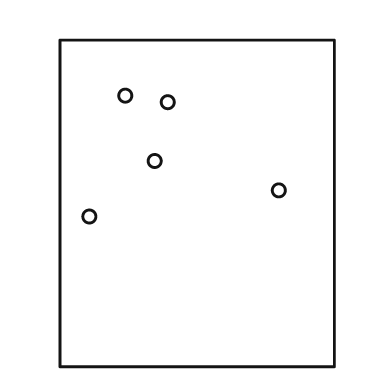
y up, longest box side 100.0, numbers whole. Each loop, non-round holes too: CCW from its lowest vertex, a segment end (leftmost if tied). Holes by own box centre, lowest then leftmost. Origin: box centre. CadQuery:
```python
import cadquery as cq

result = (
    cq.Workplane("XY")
    .moveTo(-42.0, -50.0)
    .lineTo(42.0, -50.0)
    .lineTo(42.0, 50.0)
    .lineTo(-42.0, 50.0)
    .close()
    .moveTo(-33.0, -4.0)
    .circle(2.0)
    .moveTo(25.0, 4.0)
    .circle(2.0)
    .moveTo(-13.0, 13.0)
    .circle(2.0)
    .moveTo(-9.0, 31.0)
    .circle(2.0)
    .moveTo(-22.0, 33.0)
    .circle(2.0)
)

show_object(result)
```